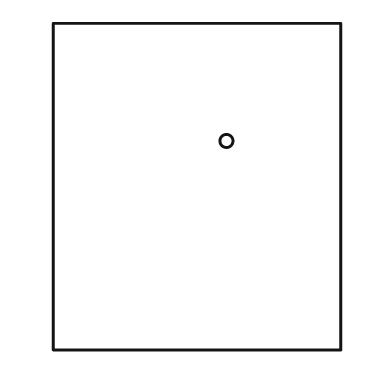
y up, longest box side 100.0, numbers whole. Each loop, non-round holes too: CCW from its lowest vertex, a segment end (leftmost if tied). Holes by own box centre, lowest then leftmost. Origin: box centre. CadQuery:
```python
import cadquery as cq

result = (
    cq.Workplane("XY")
    .moveTo(-44.0, -50.0)
    .lineTo(44.0, -50.0)
    .lineTo(44.0, 50.0)
    .lineTo(-44.0, 50.0)
    .close()
    .moveTo(9.0, 14.0)
    .circle(2.0)
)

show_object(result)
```